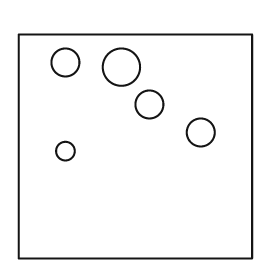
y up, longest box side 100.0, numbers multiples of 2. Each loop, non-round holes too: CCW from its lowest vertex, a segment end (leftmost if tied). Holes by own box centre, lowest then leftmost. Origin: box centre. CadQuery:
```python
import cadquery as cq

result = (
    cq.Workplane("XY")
    .moveTo(-50.0, -48.0)
    .lineTo(50.0, -48.0)
    .lineTo(50.0, 48.0)
    .lineTo(-50.0, 48.0)
    .close()
    .moveTo(-30.0, -2.0)
    .circle(4.0)
    .moveTo(28.0, 6.0)
    .circle(6.0)
    .moveTo(6.0, 18.0)
    .circle(6.0)
    .moveTo(-6.0, 34.0)
    .circle(8.0)
    .moveTo(-30.0, 36.0)
    .circle(6.0)
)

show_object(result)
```